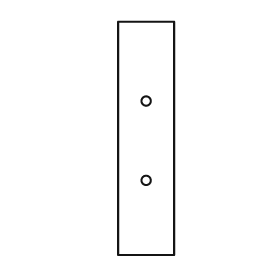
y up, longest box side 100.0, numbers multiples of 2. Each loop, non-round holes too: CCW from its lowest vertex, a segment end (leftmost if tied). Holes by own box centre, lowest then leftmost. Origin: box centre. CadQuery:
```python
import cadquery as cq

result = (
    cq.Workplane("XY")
    .moveTo(-12.0, -50.0)
    .lineTo(12.0, -50.0)
    .lineTo(12.0, 50.0)
    .lineTo(-12.0, 50.0)
    .close()
    .moveTo(0.0, -18.0)
    .circle(2.0)
    .moveTo(0.0, 16.0)
    .circle(2.0)
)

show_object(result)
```